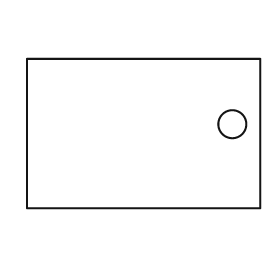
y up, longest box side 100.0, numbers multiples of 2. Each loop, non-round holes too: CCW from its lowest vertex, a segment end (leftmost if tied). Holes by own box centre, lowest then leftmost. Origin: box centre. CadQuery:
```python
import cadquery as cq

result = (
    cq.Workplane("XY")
    .moveTo(-50.0, -32.0)
    .lineTo(50.0, -32.0)
    .lineTo(50.0, 32.0)
    .lineTo(-50.0, 32.0)
    .close()
    .moveTo(38.0, 4.0)
    .circle(6.0)
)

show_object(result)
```